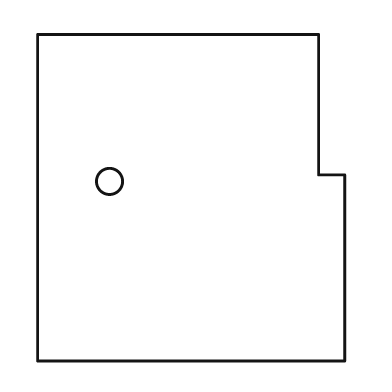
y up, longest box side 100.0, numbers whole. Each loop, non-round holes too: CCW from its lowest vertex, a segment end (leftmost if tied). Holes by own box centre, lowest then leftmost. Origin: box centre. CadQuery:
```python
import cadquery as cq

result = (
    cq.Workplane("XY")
    .moveTo(-47.0, -50.0)
    .lineTo(47.0, -50.0)
    .lineTo(47.0, 7.0)
    .lineTo(39.0, 7.0)
    .lineTo(39.0, 50.0)
    .lineTo(-47.0, 50.0)
    .close()
    .moveTo(-25.0, 5.0)
    .circle(4.0)
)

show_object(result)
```